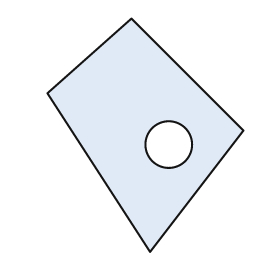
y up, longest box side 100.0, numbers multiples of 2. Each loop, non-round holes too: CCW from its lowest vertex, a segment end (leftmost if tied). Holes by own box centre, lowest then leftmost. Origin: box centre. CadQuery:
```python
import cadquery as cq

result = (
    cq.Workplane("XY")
    .moveTo(2.0, -50.0)
    .lineTo(42.0, 2.0)
    .lineTo(-6.0, 50.0)
    .lineTo(-42.0, 18.0)
    .close()
    .moveTo(10.0, -4.0)
    .circle(10.0)
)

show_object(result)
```